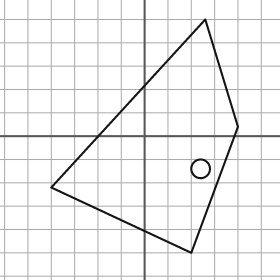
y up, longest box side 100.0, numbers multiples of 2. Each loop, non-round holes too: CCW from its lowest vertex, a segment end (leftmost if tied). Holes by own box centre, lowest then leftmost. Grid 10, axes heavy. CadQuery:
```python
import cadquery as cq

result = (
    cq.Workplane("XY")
    .moveTo(20.0, -50.0)
    .lineTo(40.0, 4.0)
    .lineTo(26.0, 50.0)
    .lineTo(-40.0, -22.0)
    .close()
    .moveTo(24.0, -14.0)
    .circle(4.0)
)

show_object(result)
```